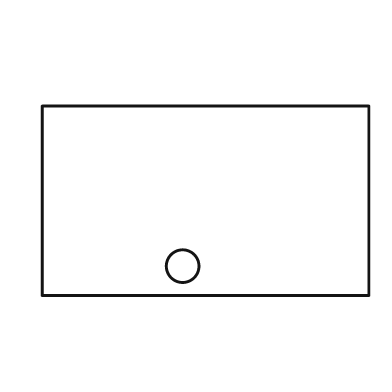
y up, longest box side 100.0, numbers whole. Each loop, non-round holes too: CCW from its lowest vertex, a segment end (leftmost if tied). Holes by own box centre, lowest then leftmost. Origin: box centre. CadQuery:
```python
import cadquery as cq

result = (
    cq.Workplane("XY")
    .moveTo(-50.0, -29.0)
    .lineTo(50.0, -29.0)
    .lineTo(50.0, 29.0)
    .lineTo(-50.0, 29.0)
    .close()
    .moveTo(-7.0, -20.0)
    .circle(5.0)
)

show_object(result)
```